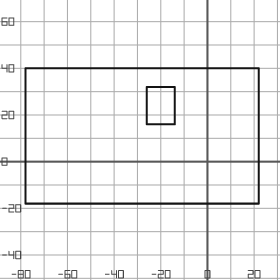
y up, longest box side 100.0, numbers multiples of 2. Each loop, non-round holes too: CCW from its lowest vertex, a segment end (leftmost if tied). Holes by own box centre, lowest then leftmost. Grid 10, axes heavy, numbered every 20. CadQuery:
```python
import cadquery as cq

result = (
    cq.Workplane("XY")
    .moveTo(-78.0, -18.0)
    .lineTo(22.0, -18.0)
    .lineTo(22.0, 40.0)
    .lineTo(-78.0, 40.0)
    .close()
    .moveTo(-26.0, 16.0)
    .lineTo(-14.0, 16.0)
    .lineTo(-14.0, 32.0)
    .lineTo(-26.0, 32.0)
    .close()
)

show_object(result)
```